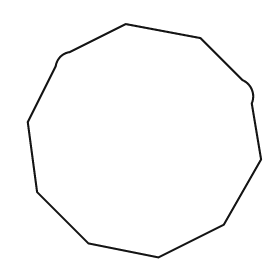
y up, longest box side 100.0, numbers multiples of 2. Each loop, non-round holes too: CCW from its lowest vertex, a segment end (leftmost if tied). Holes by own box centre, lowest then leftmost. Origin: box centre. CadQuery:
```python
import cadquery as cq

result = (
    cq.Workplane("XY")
    .moveTo(6.0, -50.0)
    .lineTo(34.0, -36.0)
    .lineTo(50.0, -8.0)
    .lineTo(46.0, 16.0)
    .threePointArc((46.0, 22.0), (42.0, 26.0))
    .lineTo(24.0, 44.0)
    .lineTo(-8.0, 50.0)
    .lineTo(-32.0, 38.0)
    .threePointArc((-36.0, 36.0), (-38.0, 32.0))
    .lineTo(-50.0, 8.0)
    .lineTo(-46.0, -22.0)
    .lineTo(-24.0, -44.0)
    .close()
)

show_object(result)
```